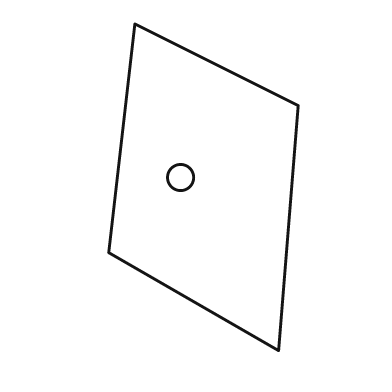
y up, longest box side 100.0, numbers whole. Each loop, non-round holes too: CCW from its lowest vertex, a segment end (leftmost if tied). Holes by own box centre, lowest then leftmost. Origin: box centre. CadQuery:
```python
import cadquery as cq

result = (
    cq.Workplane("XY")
    .moveTo(23.0, -50.0)
    .lineTo(29.0, 25.0)
    .lineTo(-21.0, 50.0)
    .lineTo(-29.0, -20.0)
    .close()
    .moveTo(-7.0, 3.0)
    .circle(4.0)
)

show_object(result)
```